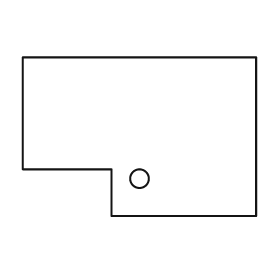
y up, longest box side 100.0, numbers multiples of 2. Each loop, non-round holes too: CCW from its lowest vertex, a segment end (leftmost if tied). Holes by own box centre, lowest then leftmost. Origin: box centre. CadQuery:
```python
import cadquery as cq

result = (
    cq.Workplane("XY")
    .moveTo(-12.0, -34.0)
    .lineTo(50.0, -34.0)
    .lineTo(50.0, 34.0)
    .lineTo(-50.0, 34.0)
    .lineTo(-50.0, -14.0)
    .lineTo(-12.0, -14.0)
    .close()
    .moveTo(0.0, -18.0)
    .circle(4.0)
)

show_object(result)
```